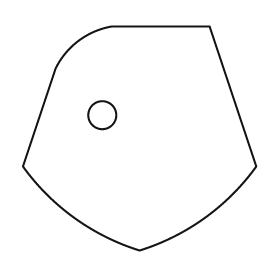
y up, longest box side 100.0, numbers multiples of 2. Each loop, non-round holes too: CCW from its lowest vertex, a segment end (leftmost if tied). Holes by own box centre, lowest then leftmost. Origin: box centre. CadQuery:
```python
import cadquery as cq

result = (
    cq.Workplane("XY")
    .moveTo(0.0, -48.0)
    .threePointArc((28.0, -34.0), (50.0, -12.0))
    .lineTo(30.0, 48.0)
    .lineTo(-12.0, 48.0)
    .threePointArc((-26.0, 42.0), (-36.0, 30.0))
    .lineTo(-50.0, -12.0)
    .threePointArc((-28.0, -34.0), (0.0, -48.0))
    .close()
    .moveTo(-16.0, 10.0)
    .circle(6.0)
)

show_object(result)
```